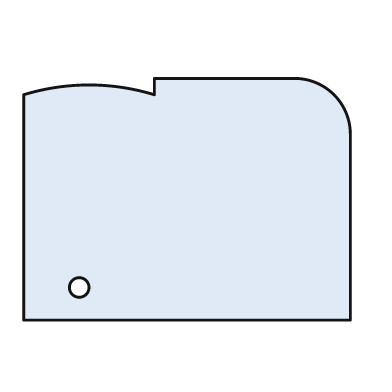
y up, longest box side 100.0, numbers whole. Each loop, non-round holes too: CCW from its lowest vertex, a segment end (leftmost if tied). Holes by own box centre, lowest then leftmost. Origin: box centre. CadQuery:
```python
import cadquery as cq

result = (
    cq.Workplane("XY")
    .moveTo(-50.0, -37.0)
    .lineTo(50.0, -37.0)
    .lineTo(50.0, 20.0)
    .threePointArc((45.0, 32.0), (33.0, 37.0))
    .lineTo(-10.0, 37.0)
    .lineTo(-10.0, 32.0)
    .threePointArc((-30.0, 35.0), (-50.0, 32.0))
    .close()
    .moveTo(-33.0, -27.0)
    .circle(3.0)
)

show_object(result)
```